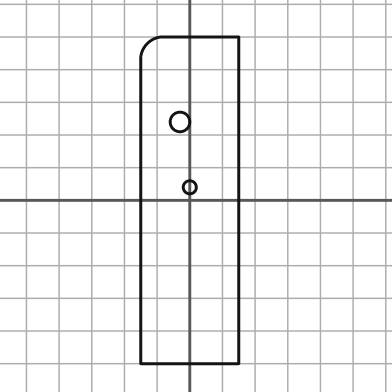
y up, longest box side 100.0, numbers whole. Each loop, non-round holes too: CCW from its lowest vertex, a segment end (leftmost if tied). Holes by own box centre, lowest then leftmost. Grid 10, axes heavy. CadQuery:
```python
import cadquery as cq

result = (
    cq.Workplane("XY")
    .moveTo(-15.0, -50.0)
    .lineTo(15.0, -50.0)
    .lineTo(15.0, 50.0)
    .lineTo(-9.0, 50.0)
    .threePointArc((-13.0, 48.0), (-15.0, 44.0))
    .close()
    .moveTo(0.0, 4.0)
    .circle(2.0)
    .moveTo(-3.0, 24.0)
    .circle(3.0)
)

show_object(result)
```